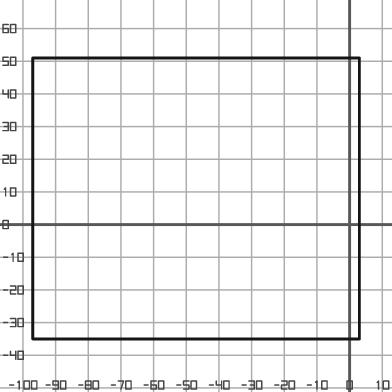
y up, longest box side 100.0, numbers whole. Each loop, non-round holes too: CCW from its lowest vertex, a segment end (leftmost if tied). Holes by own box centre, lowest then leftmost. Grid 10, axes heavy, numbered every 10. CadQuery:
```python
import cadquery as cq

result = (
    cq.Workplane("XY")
    .moveTo(-97.0, -35.0)
    .lineTo(3.0, -35.0)
    .lineTo(3.0, 51.0)
    .lineTo(-97.0, 51.0)
    .close()
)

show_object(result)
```